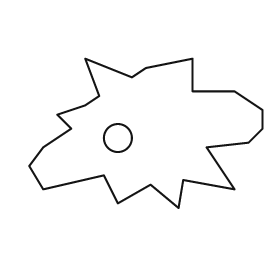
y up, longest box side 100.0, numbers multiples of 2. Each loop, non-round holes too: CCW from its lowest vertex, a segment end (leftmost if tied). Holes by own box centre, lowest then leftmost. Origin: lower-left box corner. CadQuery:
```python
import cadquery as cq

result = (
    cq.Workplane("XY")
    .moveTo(64.0, 0.0)
    .lineTo(66.0, 12.0)
    .lineTo(88.0, 8.0)
    .lineTo(76.0, 26.0)
    .lineTo(94.0, 28.0)
    .lineTo(100.0, 34.0)
    .lineTo(100.0, 42.0)
    .lineTo(88.0, 50.0)
    .lineTo(70.0, 50.0)
    .lineTo(70.0, 64.0)
    .lineTo(50.0, 60.0)
    .lineTo(44.0, 56.0)
    .lineTo(24.0, 64.0)
    .lineTo(30.0, 48.0)
    .lineTo(24.0, 44.0)
    .lineTo(12.0, 40.0)
    .lineTo(18.0, 34.0)
    .lineTo(6.0, 26.0)
    .lineTo(0.0, 18.0)
    .lineTo(6.0, 8.0)
    .lineTo(32.0, 14.0)
    .lineTo(38.0, 2.0)
    .lineTo(52.0, 10.0)
    .close()
    .moveTo(38.0, 30.0)
    .circle(6.0)
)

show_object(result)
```